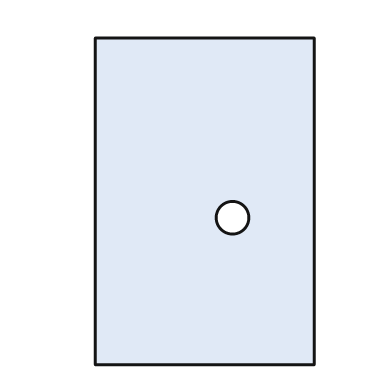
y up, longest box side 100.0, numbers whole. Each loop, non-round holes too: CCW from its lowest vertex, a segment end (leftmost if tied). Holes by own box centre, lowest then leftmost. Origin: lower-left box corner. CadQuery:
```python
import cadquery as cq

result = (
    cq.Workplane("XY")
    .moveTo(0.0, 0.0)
    .lineTo(67.0, 0.0)
    .lineTo(67.0, 100.0)
    .lineTo(0.0, 100.0)
    .close()
    .moveTo(42.0, 45.0)
    .circle(5.0)
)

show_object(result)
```